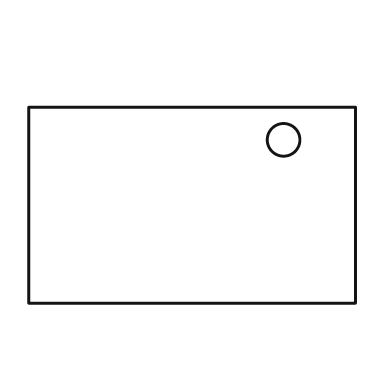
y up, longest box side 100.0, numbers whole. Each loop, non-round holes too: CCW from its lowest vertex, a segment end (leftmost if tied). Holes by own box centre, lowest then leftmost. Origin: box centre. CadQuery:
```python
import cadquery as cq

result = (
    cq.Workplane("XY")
    .moveTo(-50.0, -30.0)
    .lineTo(50.0, -30.0)
    .lineTo(50.0, 30.0)
    .lineTo(-50.0, 30.0)
    .close()
    .moveTo(28.0, 20.0)
    .circle(5.0)
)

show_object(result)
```